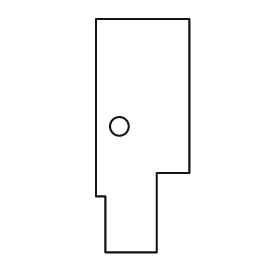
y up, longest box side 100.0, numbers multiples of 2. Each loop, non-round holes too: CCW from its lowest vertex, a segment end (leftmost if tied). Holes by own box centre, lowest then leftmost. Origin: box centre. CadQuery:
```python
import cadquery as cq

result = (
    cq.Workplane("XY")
    .moveTo(-16.0, -50.0)
    .lineTo(6.0, -50.0)
    .lineTo(6.0, -16.0)
    .lineTo(20.0, -16.0)
    .lineTo(20.0, 50.0)
    .lineTo(-20.0, 50.0)
    .lineTo(-20.0, -26.0)
    .lineTo(-16.0, -26.0)
    .close()
    .moveTo(-10.0, 4.0)
    .circle(4.0)
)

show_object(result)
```